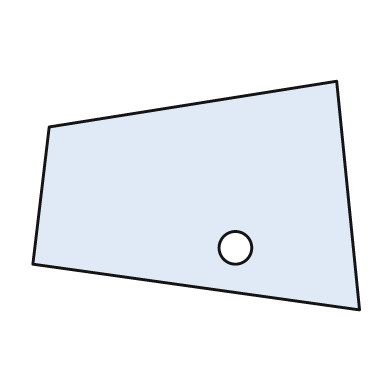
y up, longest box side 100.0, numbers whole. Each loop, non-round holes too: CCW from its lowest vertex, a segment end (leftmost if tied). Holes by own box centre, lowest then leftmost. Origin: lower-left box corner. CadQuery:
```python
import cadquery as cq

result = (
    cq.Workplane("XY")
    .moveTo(100.0, 0.0)
    .lineTo(93.0, 70.0)
    .lineTo(5.0, 56.0)
    .lineTo(0.0, 14.0)
    .close()
    .moveTo(62.0, 19.0)
    .circle(5.0)
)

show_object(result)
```